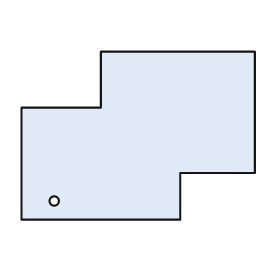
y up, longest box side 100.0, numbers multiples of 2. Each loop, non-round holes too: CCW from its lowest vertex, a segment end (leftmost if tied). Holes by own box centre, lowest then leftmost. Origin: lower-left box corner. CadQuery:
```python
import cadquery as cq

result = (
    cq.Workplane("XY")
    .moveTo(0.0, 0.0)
    .lineTo(68.0, 0.0)
    .lineTo(68.0, 20.0)
    .lineTo(100.0, 20.0)
    .lineTo(100.0, 72.0)
    .lineTo(34.0, 72.0)
    .lineTo(34.0, 48.0)
    .lineTo(0.0, 48.0)
    .close()
    .moveTo(14.0, 8.0)
    .circle(2.0)
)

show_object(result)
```